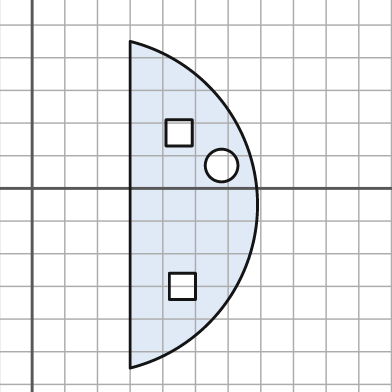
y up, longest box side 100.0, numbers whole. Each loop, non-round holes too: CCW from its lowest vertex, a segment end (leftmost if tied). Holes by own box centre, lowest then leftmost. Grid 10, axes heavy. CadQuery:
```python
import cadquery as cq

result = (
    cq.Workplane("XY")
    .moveTo(30.0, -55.0)
    .threePointArc((69.0, -5.0), (30.0, 45.0))
    .close()
    .moveTo(42.0, -34.0)
    .lineTo(50.0, -34.0)
    .lineTo(50.0, -26.0)
    .lineTo(42.0, -26.0)
    .close()
    .moveTo(58.0, 7.0)
    .circle(5.0)
    .moveTo(41.0, 13.0)
    .lineTo(49.0, 13.0)
    .lineTo(49.0, 21.0)
    .lineTo(41.0, 21.0)
    .close()
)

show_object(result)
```